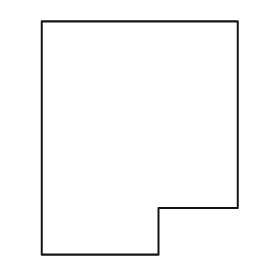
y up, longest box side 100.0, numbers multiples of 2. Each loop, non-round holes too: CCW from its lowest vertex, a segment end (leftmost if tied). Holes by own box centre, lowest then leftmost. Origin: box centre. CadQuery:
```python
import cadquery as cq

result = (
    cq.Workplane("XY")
    .moveTo(-42.0, -50.0)
    .lineTo(8.0, -50.0)
    .lineTo(8.0, -30.0)
    .lineTo(42.0, -30.0)
    .lineTo(42.0, 50.0)
    .lineTo(-42.0, 50.0)
    .close()
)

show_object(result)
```